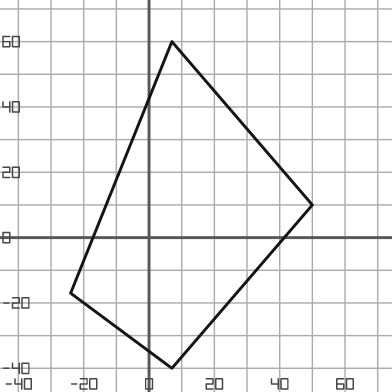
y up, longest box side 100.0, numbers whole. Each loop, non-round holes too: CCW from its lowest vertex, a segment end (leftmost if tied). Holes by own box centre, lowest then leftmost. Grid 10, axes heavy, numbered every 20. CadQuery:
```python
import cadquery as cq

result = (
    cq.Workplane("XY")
    .moveTo(7.0, -40.0)
    .lineTo(50.0, 10.0)
    .lineTo(7.0, 60.0)
    .lineTo(-24.0, -17.0)
    .close()
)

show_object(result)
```